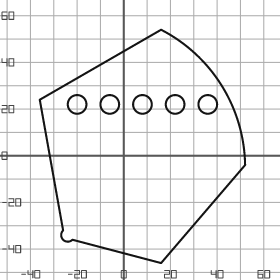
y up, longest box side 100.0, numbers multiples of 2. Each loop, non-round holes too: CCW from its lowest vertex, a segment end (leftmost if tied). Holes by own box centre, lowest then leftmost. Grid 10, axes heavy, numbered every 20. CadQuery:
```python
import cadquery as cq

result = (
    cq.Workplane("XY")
    .moveTo(16.0, -46.0)
    .lineTo(52.0, -4.0)
    .threePointArc((42.0, 30.0), (16.0, 54.0))
    .lineTo(-36.0, 24.0)
    .lineTo(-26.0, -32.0)
    .threePointArc((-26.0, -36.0), (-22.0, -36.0))
    .close()
    .moveTo(-20.0, 22.0)
    .circle(4.0)
    .moveTo(-6.0, 22.0)
    .circle(4.0)
    .moveTo(8.0, 22.0)
    .circle(4.0)
    .moveTo(22.0, 22.0)
    .circle(4.0)
    .moveTo(36.0, 22.0)
    .circle(4.0)
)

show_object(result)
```